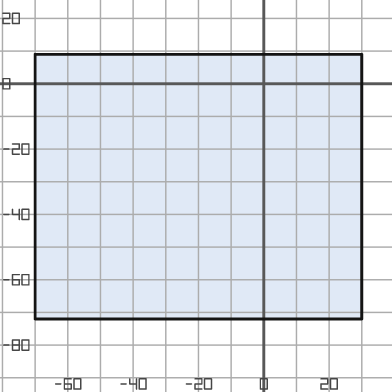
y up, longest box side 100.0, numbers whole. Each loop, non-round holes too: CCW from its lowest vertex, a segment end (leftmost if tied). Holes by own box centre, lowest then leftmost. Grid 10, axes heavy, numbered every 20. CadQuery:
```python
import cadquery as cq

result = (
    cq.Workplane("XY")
    .moveTo(-70.0, -72.0)
    .lineTo(30.0, -72.0)
    .lineTo(30.0, 9.0)
    .lineTo(-70.0, 9.0)
    .close()
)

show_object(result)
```